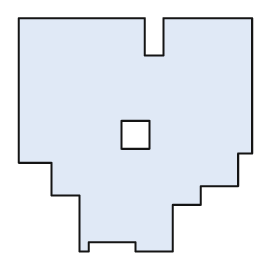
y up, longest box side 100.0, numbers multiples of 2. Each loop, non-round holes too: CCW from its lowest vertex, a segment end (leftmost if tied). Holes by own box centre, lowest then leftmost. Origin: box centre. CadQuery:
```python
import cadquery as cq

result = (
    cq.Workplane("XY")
    .moveTo(-24.0, -50.0)
    .lineTo(-20.0, -50.0)
    .lineTo(-20.0, -46.0)
    .lineTo(0.0, -46.0)
    .lineTo(0.0, -50.0)
    .lineTo(16.0, -50.0)
    .lineTo(16.0, -30.0)
    .lineTo(28.0, -30.0)
    .lineTo(28.0, -22.0)
    .lineTo(44.0, -22.0)
    .lineTo(44.0, -8.0)
    .lineTo(50.0, -8.0)
    .lineTo(50.0, 50.0)
    .lineTo(12.0, 50.0)
    .lineTo(12.0, 34.0)
    .lineTo(4.0, 34.0)
    .lineTo(4.0, 50.0)
    .lineTo(-50.0, 50.0)
    .lineTo(-50.0, -12.0)
    .lineTo(-36.0, -12.0)
    .lineTo(-36.0, -26.0)
    .lineTo(-24.0, -26.0)
    .close()
    .moveTo(-6.0, -6.0)
    .lineTo(6.0, -6.0)
    .lineTo(6.0, 6.0)
    .lineTo(-6.0, 6.0)
    .close()
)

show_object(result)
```